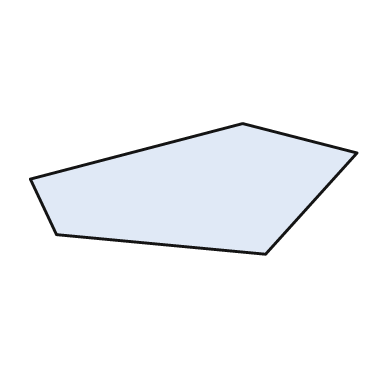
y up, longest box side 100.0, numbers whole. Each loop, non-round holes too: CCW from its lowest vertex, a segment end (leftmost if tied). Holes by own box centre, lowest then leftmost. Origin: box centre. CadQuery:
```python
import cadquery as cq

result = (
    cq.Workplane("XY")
    .moveTo(22.0, -20.0)
    .lineTo(50.0, 11.0)
    .lineTo(15.0, 20.0)
    .lineTo(-50.0, 3.0)
    .lineTo(-42.0, -14.0)
    .close()
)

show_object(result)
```